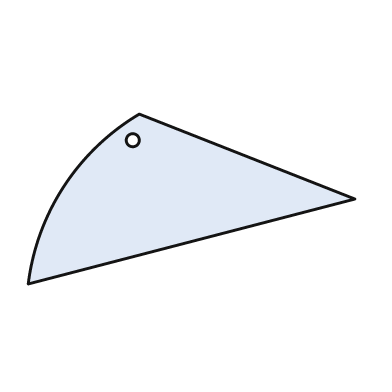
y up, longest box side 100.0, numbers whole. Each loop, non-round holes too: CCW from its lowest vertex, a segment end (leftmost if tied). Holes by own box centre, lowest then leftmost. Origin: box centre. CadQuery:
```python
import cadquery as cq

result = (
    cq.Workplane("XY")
    .moveTo(-50.0, -26.0)
    .lineTo(50.0, 0.0)
    .lineTo(-16.0, 26.0)
    .threePointArc((-39.0, 4.0), (-50.0, -26.0))
    .close()
    .moveTo(-18.0, 18.0)
    .circle(2.0)
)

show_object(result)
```